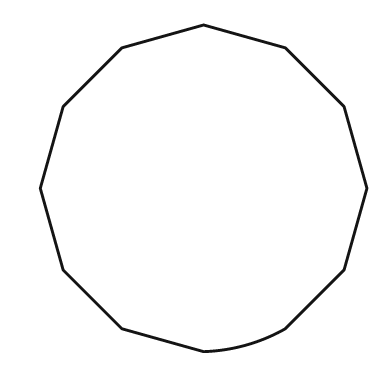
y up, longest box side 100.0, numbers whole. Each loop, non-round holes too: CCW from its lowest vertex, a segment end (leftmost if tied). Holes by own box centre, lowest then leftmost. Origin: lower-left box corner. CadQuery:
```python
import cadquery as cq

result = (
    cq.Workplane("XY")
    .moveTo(50.0, 0.0)
    .threePointArc((63.0, 2.0), (75.0, 7.0))
    .lineTo(93.0, 25.0)
    .lineTo(100.0, 50.0)
    .lineTo(93.0, 75.0)
    .lineTo(75.0, 93.0)
    .lineTo(50.0, 100.0)
    .lineTo(25.0, 93.0)
    .lineTo(7.0, 75.0)
    .lineTo(0.0, 50.0)
    .lineTo(7.0, 25.0)
    .lineTo(25.0, 7.0)
    .close()
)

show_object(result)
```